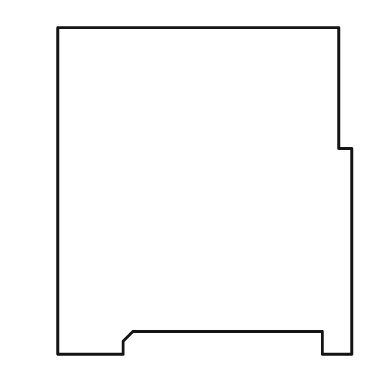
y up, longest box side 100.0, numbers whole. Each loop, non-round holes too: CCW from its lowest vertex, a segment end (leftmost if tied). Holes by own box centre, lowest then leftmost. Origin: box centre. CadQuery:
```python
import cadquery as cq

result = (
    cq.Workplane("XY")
    .moveTo(-45.0, -50.0)
    .lineTo(-25.0, -50.0)
    .lineTo(-25.0, -46.0)
    .lineTo(-22.0, -43.0)
    .lineTo(36.0, -43.0)
    .lineTo(36.0, -50.0)
    .lineTo(45.0, -50.0)
    .lineTo(45.0, 13.0)
    .lineTo(41.0, 13.0)
    .lineTo(41.0, 50.0)
    .lineTo(-45.0, 50.0)
    .close()
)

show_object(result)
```